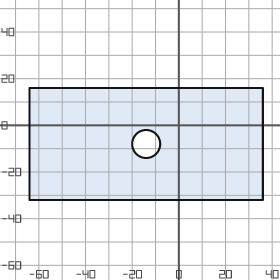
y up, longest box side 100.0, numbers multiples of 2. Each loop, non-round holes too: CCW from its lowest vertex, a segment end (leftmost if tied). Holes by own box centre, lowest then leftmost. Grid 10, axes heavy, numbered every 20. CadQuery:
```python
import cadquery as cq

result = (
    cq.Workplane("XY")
    .moveTo(-64.0, -32.0)
    .lineTo(36.0, -32.0)
    .lineTo(36.0, 16.0)
    .lineTo(-64.0, 16.0)
    .close()
    .moveTo(-14.0, -8.0)
    .circle(6.0)
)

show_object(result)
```